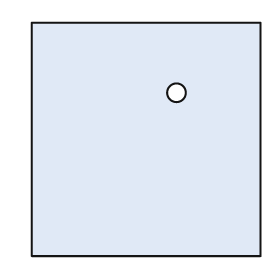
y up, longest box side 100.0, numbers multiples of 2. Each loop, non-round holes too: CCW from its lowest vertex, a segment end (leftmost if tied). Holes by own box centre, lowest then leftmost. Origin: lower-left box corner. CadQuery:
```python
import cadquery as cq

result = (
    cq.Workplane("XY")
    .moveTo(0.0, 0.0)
    .lineTo(98.0, 0.0)
    .lineTo(98.0, 100.0)
    .lineTo(0.0, 100.0)
    .close()
    .moveTo(62.0, 70.0)
    .circle(4.0)
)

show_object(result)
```